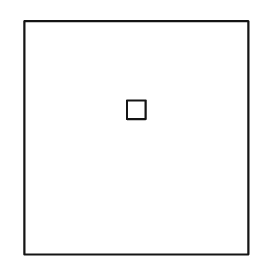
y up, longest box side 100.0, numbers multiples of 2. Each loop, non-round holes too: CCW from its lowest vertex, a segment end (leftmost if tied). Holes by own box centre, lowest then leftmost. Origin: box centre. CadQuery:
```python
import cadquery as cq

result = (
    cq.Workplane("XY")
    .moveTo(-48.0, -50.0)
    .lineTo(48.0, -50.0)
    .lineTo(48.0, 50.0)
    .lineTo(-48.0, 50.0)
    .close()
    .moveTo(-4.0, 8.0)
    .lineTo(4.0, 8.0)
    .lineTo(4.0, 16.0)
    .lineTo(-4.0, 16.0)
    .close()
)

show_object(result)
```